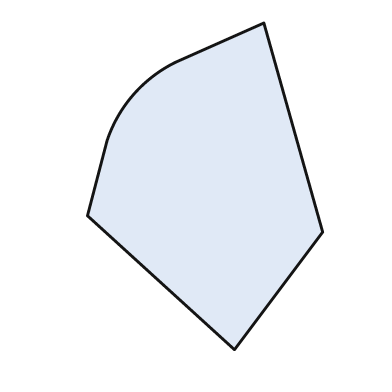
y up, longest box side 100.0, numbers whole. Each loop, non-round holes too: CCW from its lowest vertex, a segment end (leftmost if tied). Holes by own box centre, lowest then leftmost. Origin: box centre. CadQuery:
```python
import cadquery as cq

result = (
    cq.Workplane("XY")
    .moveTo(9.0, -50.0)
    .lineTo(36.0, -14.0)
    .lineTo(18.0, 50.0)
    .lineTo(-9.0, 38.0)
    .threePointArc((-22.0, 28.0), (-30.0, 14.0))
    .lineTo(-36.0, -9.0)
    .close()
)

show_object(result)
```